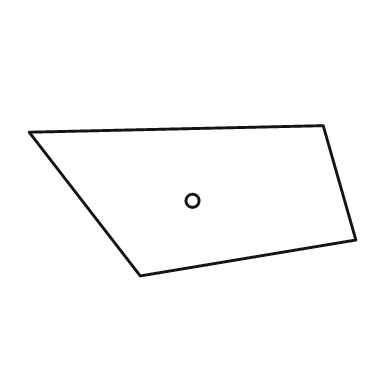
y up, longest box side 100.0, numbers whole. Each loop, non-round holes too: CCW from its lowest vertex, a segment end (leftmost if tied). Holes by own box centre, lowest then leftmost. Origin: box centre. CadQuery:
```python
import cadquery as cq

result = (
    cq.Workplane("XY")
    .moveTo(-16.0, -23.0)
    .lineTo(50.0, -12.0)
    .lineTo(40.0, 23.0)
    .lineTo(-50.0, 21.0)
    .close()
    .moveTo(0.0, 0.0)
    .circle(2.0)
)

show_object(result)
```